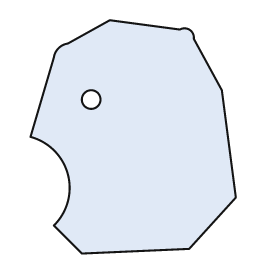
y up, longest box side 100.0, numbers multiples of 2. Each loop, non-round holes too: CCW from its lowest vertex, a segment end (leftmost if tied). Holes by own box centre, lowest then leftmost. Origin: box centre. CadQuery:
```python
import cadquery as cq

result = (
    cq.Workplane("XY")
    .moveTo(-22.0, -50.0)
    .lineTo(24.0, -48.0)
    .lineTo(44.0, -26.0)
    .lineTo(38.0, 20.0)
    .lineTo(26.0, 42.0)
    .threePointArc((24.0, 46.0), (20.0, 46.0))
    .lineTo(-10.0, 50.0)
    .lineTo(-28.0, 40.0)
    .threePointArc((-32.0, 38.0), (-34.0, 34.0))
    .lineTo(-44.0, 0.0)
    .threePointArc((-28.0, -16.0), (-34.0, -38.0))
    .close()
    .moveTo(-18.0, 16.0)
    .circle(4.0)
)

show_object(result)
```